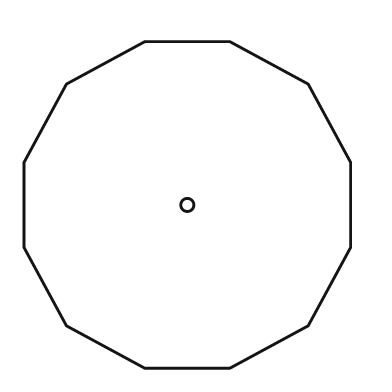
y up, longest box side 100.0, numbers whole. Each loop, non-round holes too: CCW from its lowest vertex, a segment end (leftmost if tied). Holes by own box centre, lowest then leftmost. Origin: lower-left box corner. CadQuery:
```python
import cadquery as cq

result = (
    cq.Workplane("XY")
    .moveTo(37.0, 0.0)
    .lineTo(63.0, 0.0)
    .lineTo(87.0, 13.0)
    .lineTo(100.0, 37.0)
    .lineTo(100.0, 63.0)
    .lineTo(87.0, 87.0)
    .lineTo(63.0, 100.0)
    .lineTo(37.0, 100.0)
    .lineTo(13.0, 87.0)
    .lineTo(0.0, 63.0)
    .lineTo(0.0, 37.0)
    .lineTo(13.0, 13.0)
    .close()
    .moveTo(50.0, 50.0)
    .circle(2.0)
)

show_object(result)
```